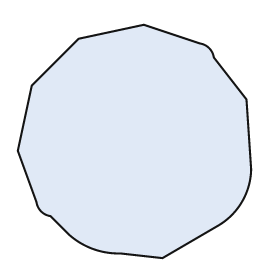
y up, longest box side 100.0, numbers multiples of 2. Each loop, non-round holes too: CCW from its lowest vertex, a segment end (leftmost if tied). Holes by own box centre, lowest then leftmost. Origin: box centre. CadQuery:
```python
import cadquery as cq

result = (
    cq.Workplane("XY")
    .moveTo(12.0, -50.0)
    .lineTo(36.0, -36.0)
    .threePointArc((46.0, -26.0), (50.0, -12.0))
    .lineTo(48.0, 18.0)
    .lineTo(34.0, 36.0)
    .threePointArc((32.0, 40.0), (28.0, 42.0))
    .lineTo(4.0, 50.0)
    .lineTo(-24.0, 44.0)
    .lineTo(-44.0, 24.0)
    .lineTo(-50.0, -4.0)
    .lineTo(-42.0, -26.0)
    .threePointArc((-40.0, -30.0), (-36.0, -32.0))
    .lineTo(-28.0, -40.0)
    .threePointArc((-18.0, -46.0), (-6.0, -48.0))
    .close()
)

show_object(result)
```